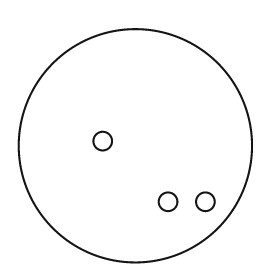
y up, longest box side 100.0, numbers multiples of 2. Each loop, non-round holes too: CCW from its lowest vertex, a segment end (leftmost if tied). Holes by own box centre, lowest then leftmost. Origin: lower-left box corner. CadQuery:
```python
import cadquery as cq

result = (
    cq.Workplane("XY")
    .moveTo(50.0, 50.0)
    .circle(50.0)
    .moveTo(64.0, 26.0)
    .circle(4.0)
    .moveTo(80.0, 26.0)
    .circle(4.0)
    .moveTo(36.0, 52.0)
    .circle(4.0)
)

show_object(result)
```